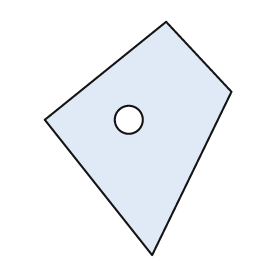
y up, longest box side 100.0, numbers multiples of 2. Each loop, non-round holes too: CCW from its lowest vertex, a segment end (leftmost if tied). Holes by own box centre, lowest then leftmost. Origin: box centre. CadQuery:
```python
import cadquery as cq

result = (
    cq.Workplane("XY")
    .moveTo(6.0, -50.0)
    .lineTo(40.0, 20.0)
    .lineTo(12.0, 50.0)
    .lineTo(-40.0, 8.0)
    .close()
    .moveTo(-4.0, 8.0)
    .circle(6.0)
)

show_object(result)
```